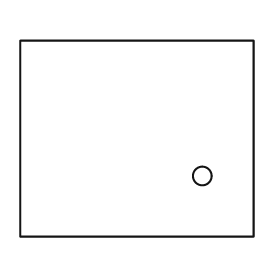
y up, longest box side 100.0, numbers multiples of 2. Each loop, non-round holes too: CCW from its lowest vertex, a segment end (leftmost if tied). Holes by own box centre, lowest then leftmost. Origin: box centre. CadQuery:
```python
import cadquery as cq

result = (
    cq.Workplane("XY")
    .moveTo(-50.0, -42.0)
    .lineTo(50.0, -42.0)
    .lineTo(50.0, 42.0)
    .lineTo(-50.0, 42.0)
    .close()
    .moveTo(28.0, -16.0)
    .circle(4.0)
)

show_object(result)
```